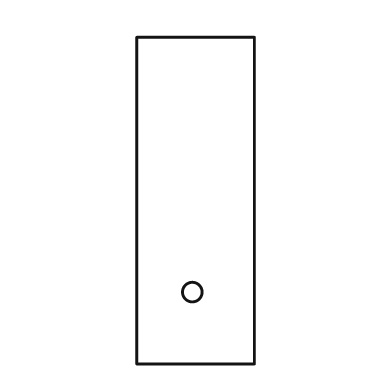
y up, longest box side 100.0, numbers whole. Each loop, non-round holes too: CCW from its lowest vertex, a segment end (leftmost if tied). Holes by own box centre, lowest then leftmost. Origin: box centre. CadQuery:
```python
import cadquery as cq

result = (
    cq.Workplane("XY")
    .moveTo(-18.0, -50.0)
    .lineTo(18.0, -50.0)
    .lineTo(18.0, 50.0)
    .lineTo(-18.0, 50.0)
    .close()
    .moveTo(-1.0, -28.0)
    .circle(3.0)
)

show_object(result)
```